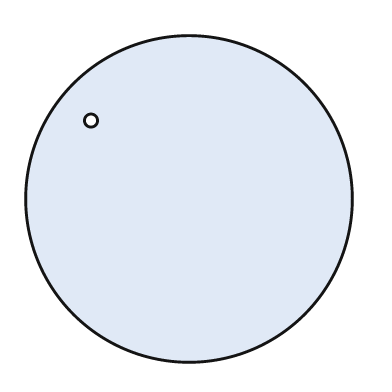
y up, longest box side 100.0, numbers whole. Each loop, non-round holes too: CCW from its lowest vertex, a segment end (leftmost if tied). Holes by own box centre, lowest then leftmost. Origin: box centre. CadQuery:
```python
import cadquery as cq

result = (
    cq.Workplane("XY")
    .moveTo(0.0, 0.0)
    .circle(50.0)
    .moveTo(-30.0, 24.0)
    .circle(2.0)
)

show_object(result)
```